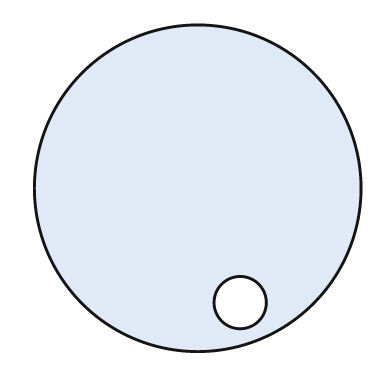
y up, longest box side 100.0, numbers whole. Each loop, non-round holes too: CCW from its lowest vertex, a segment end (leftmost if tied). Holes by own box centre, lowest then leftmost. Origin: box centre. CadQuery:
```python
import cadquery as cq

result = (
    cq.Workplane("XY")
    .moveTo(0.0, 0.0)
    .circle(50.0)
    .moveTo(13.0, -35.0)
    .circle(8.0)
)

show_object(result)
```